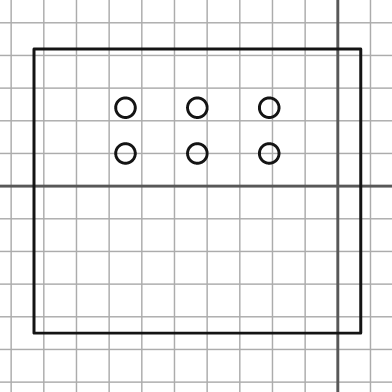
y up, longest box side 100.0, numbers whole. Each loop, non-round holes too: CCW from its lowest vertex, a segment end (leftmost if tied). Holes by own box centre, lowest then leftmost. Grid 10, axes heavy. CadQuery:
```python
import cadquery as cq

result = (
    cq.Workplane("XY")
    .moveTo(-93.0, -45.0)
    .lineTo(7.0, -45.0)
    .lineTo(7.0, 42.0)
    .lineTo(-93.0, 42.0)
    .close()
    .moveTo(-65.0, 10.0)
    .circle(3.0)
    .moveTo(-43.0, 10.0)
    .circle(3.0)
    .moveTo(-21.0, 10.0)
    .circle(3.0)
    .moveTo(-65.0, 24.0)
    .circle(3.0)
    .moveTo(-43.0, 24.0)
    .circle(3.0)
    .moveTo(-21.0, 24.0)
    .circle(3.0)
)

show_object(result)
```